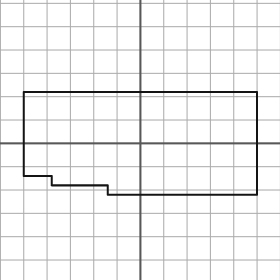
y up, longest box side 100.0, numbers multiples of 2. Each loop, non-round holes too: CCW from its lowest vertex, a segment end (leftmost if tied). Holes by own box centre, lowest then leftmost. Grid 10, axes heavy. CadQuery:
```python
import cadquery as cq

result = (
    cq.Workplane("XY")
    .moveTo(-14.0, -22.0)
    .lineTo(50.0, -22.0)
    .lineTo(50.0, 22.0)
    .lineTo(-50.0, 22.0)
    .lineTo(-50.0, -14.0)
    .lineTo(-38.0, -14.0)
    .lineTo(-38.0, -18.0)
    .lineTo(-14.0, -18.0)
    .close()
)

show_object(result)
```